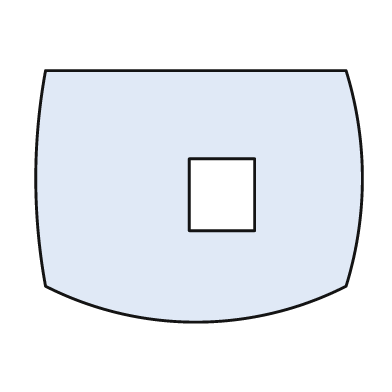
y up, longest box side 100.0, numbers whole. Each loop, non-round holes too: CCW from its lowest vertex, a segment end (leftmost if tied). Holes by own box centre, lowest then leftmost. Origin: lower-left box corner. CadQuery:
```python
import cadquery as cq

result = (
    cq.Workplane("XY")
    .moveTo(3.0, 11.0)
    .threePointArc((49.0, 0.0), (95.0, 11.0))
    .threePointArc((100.0, 44.0), (95.0, 77.0))
    .lineTo(3.0, 77.0)
    .threePointArc((0.0, 44.0), (3.0, 11.0))
    .close()
    .moveTo(47.0, 28.0)
    .lineTo(67.0, 28.0)
    .lineTo(67.0, 50.0)
    .lineTo(47.0, 50.0)
    .close()
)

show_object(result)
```